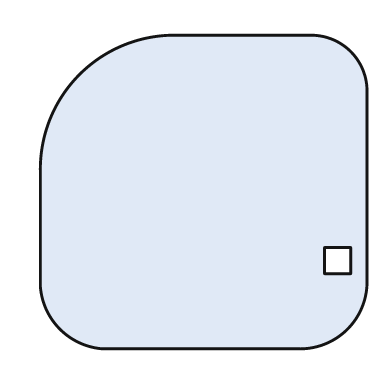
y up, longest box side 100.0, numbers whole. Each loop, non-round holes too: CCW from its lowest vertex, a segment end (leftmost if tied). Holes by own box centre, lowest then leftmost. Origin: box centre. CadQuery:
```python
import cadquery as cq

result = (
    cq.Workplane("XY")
    .moveTo(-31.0, -48.0)
    .lineTo(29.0, -48.0)
    .threePointArc((44.0, -42.0), (50.0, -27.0))
    .lineTo(50.0, 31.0)
    .threePointArc((45.0, 43.0), (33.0, 48.0))
    .lineTo(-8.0, 48.0)
    .threePointArc((-38.0, 36.0), (-50.0, 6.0))
    .lineTo(-50.0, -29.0)
    .threePointArc((-44.0, -42.0), (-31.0, -48.0))
    .close()
    .moveTo(37.0, -25.0)
    .lineTo(45.0, -25.0)
    .lineTo(45.0, -17.0)
    .lineTo(37.0, -17.0)
    .close()
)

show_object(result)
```